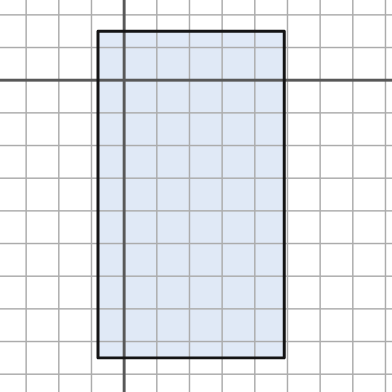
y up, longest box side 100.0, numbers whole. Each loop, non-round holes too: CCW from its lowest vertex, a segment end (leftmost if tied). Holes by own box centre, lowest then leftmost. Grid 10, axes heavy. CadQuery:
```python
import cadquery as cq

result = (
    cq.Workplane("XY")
    .moveTo(-8.0, -85.0)
    .lineTo(49.0, -85.0)
    .lineTo(49.0, 15.0)
    .lineTo(-8.0, 15.0)
    .close()
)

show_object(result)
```